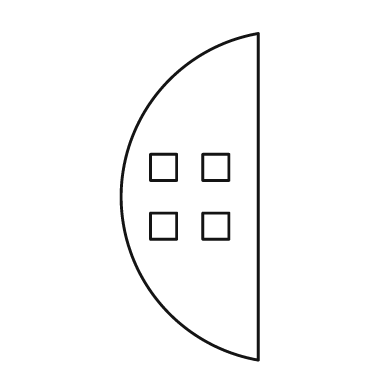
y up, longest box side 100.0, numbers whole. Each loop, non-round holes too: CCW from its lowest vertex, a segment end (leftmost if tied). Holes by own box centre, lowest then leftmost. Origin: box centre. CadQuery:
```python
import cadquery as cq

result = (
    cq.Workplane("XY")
    .moveTo(21.0, -50.0)
    .lineTo(21.0, 50.0)
    .threePointArc((-21.0, 0.0), (21.0, -50.0))
    .close()
    .moveTo(-12.0, -13.0)
    .lineTo(-4.0, -13.0)
    .lineTo(-4.0, -5.0)
    .lineTo(-12.0, -5.0)
    .close()
    .moveTo(4.0, -13.0)
    .lineTo(12.0, -13.0)
    .lineTo(12.0, -5.0)
    .lineTo(4.0, -5.0)
    .close()
    .moveTo(-12.0, 5.0)
    .lineTo(-4.0, 5.0)
    .lineTo(-4.0, 13.0)
    .lineTo(-12.0, 13.0)
    .close()
    .moveTo(4.0, 5.0)
    .lineTo(12.0, 5.0)
    .lineTo(12.0, 13.0)
    .lineTo(4.0, 13.0)
    .close()
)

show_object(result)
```